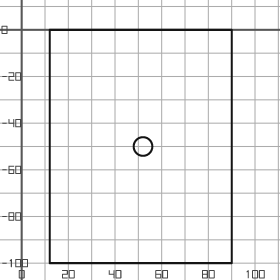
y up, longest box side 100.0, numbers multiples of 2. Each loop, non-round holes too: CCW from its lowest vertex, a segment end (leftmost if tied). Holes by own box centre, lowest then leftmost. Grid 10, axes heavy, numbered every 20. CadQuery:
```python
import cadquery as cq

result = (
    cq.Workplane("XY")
    .moveTo(12.0, -100.0)
    .lineTo(90.0, -100.0)
    .lineTo(90.0, 0.0)
    .lineTo(12.0, 0.0)
    .close()
    .moveTo(52.0, -50.0)
    .circle(4.0)
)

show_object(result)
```